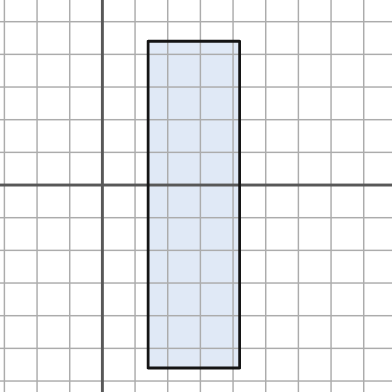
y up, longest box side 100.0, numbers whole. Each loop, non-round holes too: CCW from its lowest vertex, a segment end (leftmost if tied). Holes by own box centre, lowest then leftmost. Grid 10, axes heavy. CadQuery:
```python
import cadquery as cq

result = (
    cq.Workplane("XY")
    .moveTo(14.0, -56.0)
    .lineTo(42.0, -56.0)
    .lineTo(42.0, 44.0)
    .lineTo(14.0, 44.0)
    .close()
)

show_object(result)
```